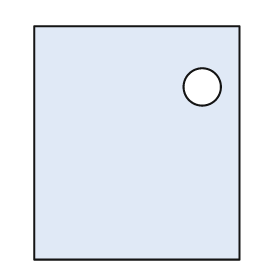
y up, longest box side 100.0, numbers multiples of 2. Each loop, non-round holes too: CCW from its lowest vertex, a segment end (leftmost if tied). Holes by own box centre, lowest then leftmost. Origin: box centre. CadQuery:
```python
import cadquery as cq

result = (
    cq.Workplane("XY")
    .moveTo(-44.0, -50.0)
    .lineTo(44.0, -50.0)
    .lineTo(44.0, 50.0)
    .lineTo(-44.0, 50.0)
    .close()
    .moveTo(28.0, 24.0)
    .circle(8.0)
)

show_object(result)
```